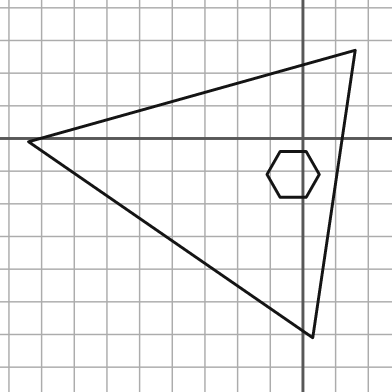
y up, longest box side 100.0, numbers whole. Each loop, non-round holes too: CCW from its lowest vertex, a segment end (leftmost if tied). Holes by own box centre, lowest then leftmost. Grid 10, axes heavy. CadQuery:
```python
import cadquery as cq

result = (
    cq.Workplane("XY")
    .moveTo(3.0, -61.0)
    .lineTo(16.0, 27.0)
    .lineTo(-84.0, -1.0)
    .close()
    .moveTo(-7.0, -18.0)
    .lineTo(1.0, -18.0)
    .lineTo(5.0, -11.0)
    .lineTo(1.0, -4.0)
    .lineTo(-7.0, -4.0)
    .lineTo(-11.0, -11.0)
    .close()
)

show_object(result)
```